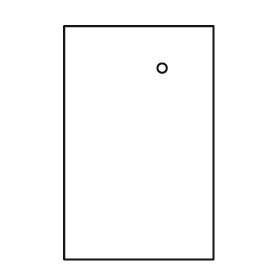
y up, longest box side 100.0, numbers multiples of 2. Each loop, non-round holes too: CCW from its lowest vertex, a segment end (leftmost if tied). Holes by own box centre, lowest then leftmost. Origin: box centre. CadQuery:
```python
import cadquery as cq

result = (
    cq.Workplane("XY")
    .moveTo(-32.0, -50.0)
    .lineTo(32.0, -50.0)
    .lineTo(32.0, 50.0)
    .lineTo(-32.0, 50.0)
    .close()
    .moveTo(10.0, 32.0)
    .circle(2.0)
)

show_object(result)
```